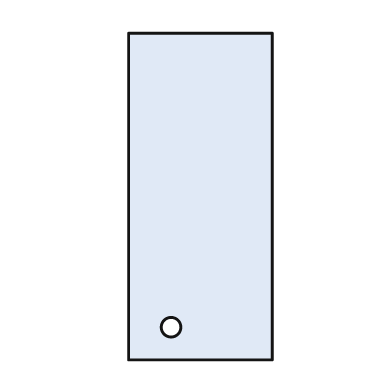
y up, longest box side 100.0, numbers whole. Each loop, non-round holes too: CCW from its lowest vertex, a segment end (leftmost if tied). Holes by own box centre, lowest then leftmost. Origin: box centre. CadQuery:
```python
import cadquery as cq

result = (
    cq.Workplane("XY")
    .moveTo(-22.0, -50.0)
    .lineTo(22.0, -50.0)
    .lineTo(22.0, 50.0)
    .lineTo(-22.0, 50.0)
    .close()
    .moveTo(-9.0, -40.0)
    .circle(3.0)
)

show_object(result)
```